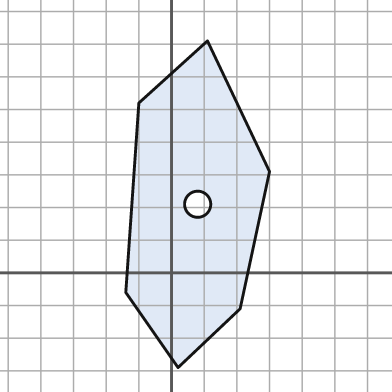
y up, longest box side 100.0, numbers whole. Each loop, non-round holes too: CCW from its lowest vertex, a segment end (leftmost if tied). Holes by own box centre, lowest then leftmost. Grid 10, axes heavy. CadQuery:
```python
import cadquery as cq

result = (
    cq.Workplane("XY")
    .moveTo(2.0, -29.0)
    .lineTo(21.0, -11.0)
    .lineTo(30.0, 31.0)
    .lineTo(11.0, 71.0)
    .lineTo(-10.0, 52.0)
    .lineTo(-14.0, -6.0)
    .close()
    .moveTo(8.0, 21.0)
    .circle(4.0)
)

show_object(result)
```